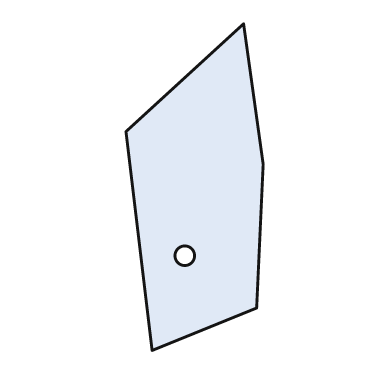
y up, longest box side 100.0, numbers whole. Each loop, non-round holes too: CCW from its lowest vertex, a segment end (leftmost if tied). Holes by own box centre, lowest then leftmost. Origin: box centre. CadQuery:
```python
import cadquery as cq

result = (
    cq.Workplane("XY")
    .moveTo(-13.0, -50.0)
    .lineTo(19.0, -37.0)
    .lineTo(21.0, 7.0)
    .lineTo(15.0, 50.0)
    .lineTo(-21.0, 17.0)
    .close()
    .moveTo(-3.0, -21.0)
    .circle(3.0)
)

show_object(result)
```